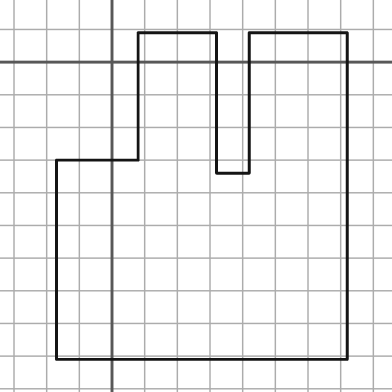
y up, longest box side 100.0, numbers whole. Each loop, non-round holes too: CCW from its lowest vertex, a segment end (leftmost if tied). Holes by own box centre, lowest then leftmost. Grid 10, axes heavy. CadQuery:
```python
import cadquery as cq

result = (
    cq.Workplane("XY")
    .moveTo(-17.0, -91.0)
    .lineTo(72.0, -91.0)
    .lineTo(72.0, 9.0)
    .lineTo(42.0, 9.0)
    .lineTo(42.0, -34.0)
    .lineTo(32.0, -34.0)
    .lineTo(32.0, 9.0)
    .lineTo(8.0, 9.0)
    .lineTo(8.0, -30.0)
    .lineTo(-17.0, -30.0)
    .close()
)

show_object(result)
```